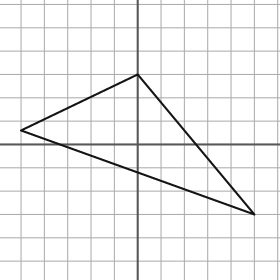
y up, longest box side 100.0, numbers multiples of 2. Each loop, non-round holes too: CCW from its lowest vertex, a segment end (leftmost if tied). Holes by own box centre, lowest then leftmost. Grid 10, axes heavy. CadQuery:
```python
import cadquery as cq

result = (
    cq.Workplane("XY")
    .moveTo(50.0, -30.0)
    .lineTo(0.0, 30.0)
    .lineTo(-50.0, 6.0)
    .close()
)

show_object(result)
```